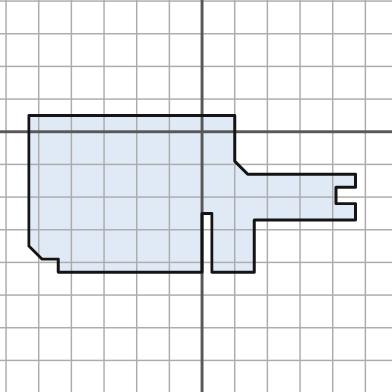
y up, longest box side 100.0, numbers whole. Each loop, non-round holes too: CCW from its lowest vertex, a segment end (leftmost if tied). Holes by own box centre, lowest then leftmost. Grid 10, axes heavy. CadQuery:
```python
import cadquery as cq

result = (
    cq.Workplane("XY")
    .moveTo(-44.0, -43.0)
    .lineTo(0.0, -43.0)
    .lineTo(0.0, -25.0)
    .lineTo(3.0, -25.0)
    .lineTo(3.0, -43.0)
    .lineTo(16.0, -43.0)
    .lineTo(16.0, -27.0)
    .lineTo(47.0, -27.0)
    .lineTo(47.0, -22.0)
    .lineTo(41.0, -22.0)
    .lineTo(41.0, -17.0)
    .lineTo(47.0, -17.0)
    .lineTo(47.0, -13.0)
    .lineTo(14.0, -13.0)
    .lineTo(10.0, -9.0)
    .lineTo(10.0, 5.0)
    .lineTo(-53.0, 5.0)
    .lineTo(-53.0, -35.0)
    .lineTo(-49.0, -39.0)
    .lineTo(-44.0, -39.0)
    .close()
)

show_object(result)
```